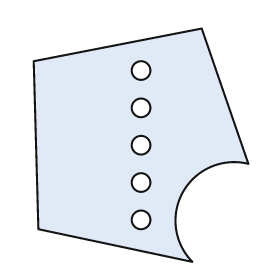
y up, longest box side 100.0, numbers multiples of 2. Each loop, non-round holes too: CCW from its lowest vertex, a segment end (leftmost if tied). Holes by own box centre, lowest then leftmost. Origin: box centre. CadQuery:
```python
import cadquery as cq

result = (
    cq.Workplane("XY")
    .moveTo(22.0, -50.0)
    .threePointArc((18.0, -20.0), (46.0, -8.0))
    .lineTo(26.0, 50.0)
    .lineTo(-46.0, 36.0)
    .lineTo(-44.0, -36.0)
    .close()
    .moveTo(0.0, -32.0)
    .circle(4.0)
    .moveTo(0.0, -16.0)
    .circle(4.0)
    .moveTo(0.0, 0.0)
    .circle(4.0)
    .moveTo(0.0, 16.0)
    .circle(4.0)
    .moveTo(0.0, 32.0)
    .circle(4.0)
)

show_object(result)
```